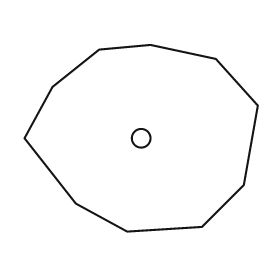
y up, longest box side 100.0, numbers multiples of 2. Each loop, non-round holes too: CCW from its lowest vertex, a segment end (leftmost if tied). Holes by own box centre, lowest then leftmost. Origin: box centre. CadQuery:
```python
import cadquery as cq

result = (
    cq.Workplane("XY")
    .moveTo(-6.0, -40.0)
    .lineTo(26.0, -38.0)
    .lineTo(44.0, -20.0)
    .lineTo(50.0, 14.0)
    .lineTo(32.0, 34.0)
    .lineTo(4.0, 40.0)
    .lineTo(-18.0, 38.0)
    .lineTo(-38.0, 22.0)
    .lineTo(-50.0, 0.0)
    .lineTo(-28.0, -28.0)
    .close()
    .moveTo(0.0, 0.0)
    .circle(4.0)
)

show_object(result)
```